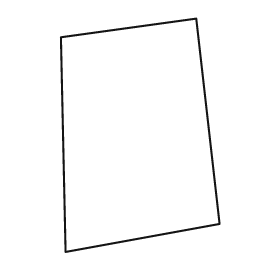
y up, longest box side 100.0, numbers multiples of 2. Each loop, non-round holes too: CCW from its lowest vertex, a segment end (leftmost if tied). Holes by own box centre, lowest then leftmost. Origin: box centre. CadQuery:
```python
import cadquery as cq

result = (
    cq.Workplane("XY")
    .moveTo(-32.0, -50.0)
    .lineTo(34.0, -38.0)
    .lineTo(24.0, 50.0)
    .lineTo(-34.0, 42.0)
    .close()
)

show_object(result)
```